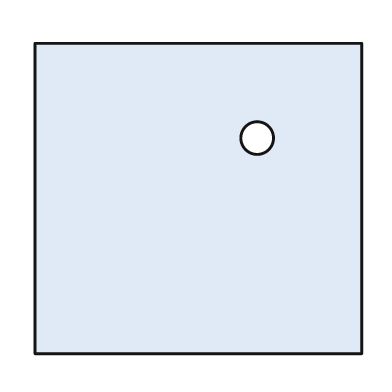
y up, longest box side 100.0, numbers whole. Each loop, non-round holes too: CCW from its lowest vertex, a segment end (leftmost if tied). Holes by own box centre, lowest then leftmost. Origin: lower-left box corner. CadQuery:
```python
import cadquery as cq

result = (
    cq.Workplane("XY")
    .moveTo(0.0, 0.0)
    .lineTo(100.0, 0.0)
    .lineTo(100.0, 95.0)
    .lineTo(0.0, 95.0)
    .close()
    .moveTo(68.0, 66.0)
    .circle(5.0)
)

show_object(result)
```